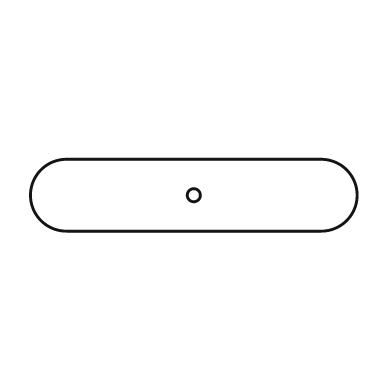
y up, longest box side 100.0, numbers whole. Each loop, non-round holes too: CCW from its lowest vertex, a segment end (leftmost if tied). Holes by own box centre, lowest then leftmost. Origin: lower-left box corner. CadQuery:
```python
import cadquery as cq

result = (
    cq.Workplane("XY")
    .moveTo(11.0, 0.0)
    .lineTo(89.0, 0.0)
    .threePointArc((100.0, 11.0), (89.0, 22.0))
    .lineTo(11.0, 22.0)
    .threePointArc((0.0, 11.0), (11.0, 0.0))
    .close()
    .moveTo(50.0, 11.0)
    .circle(2.0)
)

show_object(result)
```